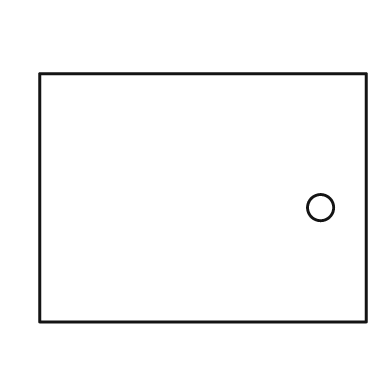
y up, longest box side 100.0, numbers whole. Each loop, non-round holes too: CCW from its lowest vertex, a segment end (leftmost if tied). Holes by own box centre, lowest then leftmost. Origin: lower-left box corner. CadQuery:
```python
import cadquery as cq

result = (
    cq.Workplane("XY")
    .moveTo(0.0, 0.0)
    .lineTo(100.0, 0.0)
    .lineTo(100.0, 76.0)
    .lineTo(0.0, 76.0)
    .close()
    .moveTo(86.0, 35.0)
    .circle(4.0)
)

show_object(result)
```